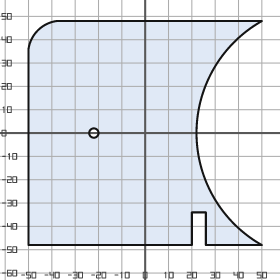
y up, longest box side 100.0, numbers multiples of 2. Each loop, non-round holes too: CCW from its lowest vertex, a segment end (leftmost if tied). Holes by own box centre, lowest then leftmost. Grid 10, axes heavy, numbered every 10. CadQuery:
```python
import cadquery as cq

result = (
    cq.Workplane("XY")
    .moveTo(-50.0, -48.0)
    .lineTo(20.0, -48.0)
    .lineTo(20.0, -34.0)
    .lineTo(26.0, -34.0)
    .lineTo(26.0, -48.0)
    .lineTo(50.0, -48.0)
    .threePointArc((22.0, 0.0), (50.0, 48.0))
    .lineTo(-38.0, 48.0)
    .threePointArc((-46.0, 44.0), (-50.0, 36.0))
    .close()
    .moveTo(-22.0, 0.0)
    .circle(2.0)
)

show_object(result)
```